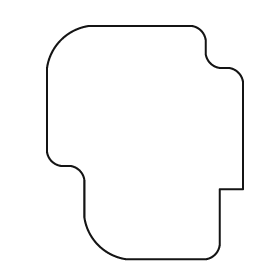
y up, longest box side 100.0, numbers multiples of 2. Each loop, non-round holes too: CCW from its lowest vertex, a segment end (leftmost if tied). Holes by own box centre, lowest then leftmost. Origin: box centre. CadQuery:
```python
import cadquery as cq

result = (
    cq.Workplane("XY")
    .moveTo(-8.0, -50.0)
    .lineTo(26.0, -50.0)
    .threePointArc((30.0, -48.0), (32.0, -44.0))
    .lineTo(32.0, -20.0)
    .lineTo(42.0, -20.0)
    .lineTo(42.0, 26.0)
    .threePointArc((40.0, 30.0), (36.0, 32.0))
    .lineTo(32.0, 32.0)
    .threePointArc((28.0, 34.0), (26.0, 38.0))
    .lineTo(26.0, 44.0)
    .threePointArc((24.0, 48.0), (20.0, 50.0))
    .lineTo(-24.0, 50.0)
    .threePointArc((-36.0, 44.0), (-42.0, 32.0))
    .lineTo(-42.0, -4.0)
    .threePointArc((-40.0, -8.0), (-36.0, -10.0))
    .lineTo(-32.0, -10.0)
    .threePointArc((-28.0, -12.0), (-26.0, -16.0))
    .lineTo(-26.0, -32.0)
    .threePointArc((-20.0, -44.0), (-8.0, -50.0))
    .close()
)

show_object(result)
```